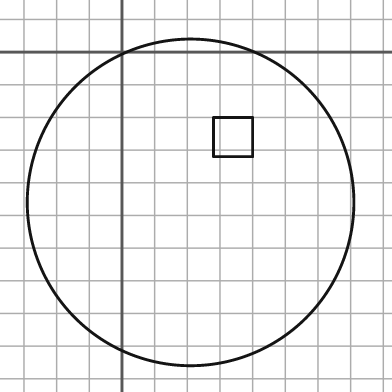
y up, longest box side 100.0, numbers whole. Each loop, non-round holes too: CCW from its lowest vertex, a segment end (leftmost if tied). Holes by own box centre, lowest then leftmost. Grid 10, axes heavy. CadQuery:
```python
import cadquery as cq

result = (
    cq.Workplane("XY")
    .moveTo(21.0, -46.0)
    .circle(50.0)
    .moveTo(28.0, -32.0)
    .lineTo(40.0, -32.0)
    .lineTo(40.0, -20.0)
    .lineTo(28.0, -20.0)
    .close()
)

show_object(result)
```